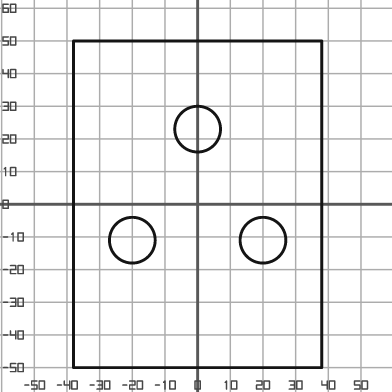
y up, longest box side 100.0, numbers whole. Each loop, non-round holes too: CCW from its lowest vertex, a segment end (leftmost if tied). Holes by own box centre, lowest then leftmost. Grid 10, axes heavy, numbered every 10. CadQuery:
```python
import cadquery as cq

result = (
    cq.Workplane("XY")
    .moveTo(-38.0, -50.0)
    .lineTo(38.0, -50.0)
    .lineTo(38.0, 50.0)
    .lineTo(-38.0, 50.0)
    .close()
    .moveTo(-20.0, -11.0)
    .circle(7.0)
    .moveTo(20.0, -11.0)
    .circle(7.0)
    .moveTo(0.0, 23.0)
    .circle(7.0)
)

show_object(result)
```